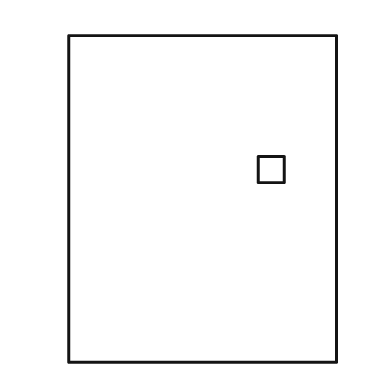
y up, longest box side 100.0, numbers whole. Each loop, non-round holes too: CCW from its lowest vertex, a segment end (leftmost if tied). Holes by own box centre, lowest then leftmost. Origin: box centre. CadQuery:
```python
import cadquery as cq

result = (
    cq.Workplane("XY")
    .moveTo(-41.0, -50.0)
    .lineTo(41.0, -50.0)
    .lineTo(41.0, 50.0)
    .lineTo(-41.0, 50.0)
    .close()
    .moveTo(17.0, 5.0)
    .lineTo(25.0, 5.0)
    .lineTo(25.0, 13.0)
    .lineTo(17.0, 13.0)
    .close()
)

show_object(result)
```